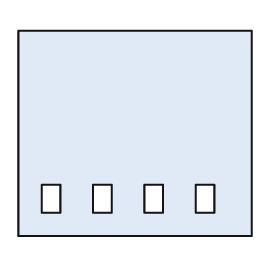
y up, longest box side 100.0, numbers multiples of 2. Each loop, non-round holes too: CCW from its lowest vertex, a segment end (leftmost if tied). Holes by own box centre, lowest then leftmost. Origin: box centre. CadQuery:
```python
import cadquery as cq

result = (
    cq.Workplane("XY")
    .moveTo(-50.0, -44.0)
    .lineTo(50.0, -44.0)
    .lineTo(50.0, 44.0)
    .lineTo(-50.0, 44.0)
    .close()
    .moveTo(-40.0, -34.0)
    .lineTo(-32.0, -34.0)
    .lineTo(-32.0, -22.0)
    .lineTo(-40.0, -22.0)
    .close()
    .moveTo(-18.0, -34.0)
    .lineTo(-10.0, -34.0)
    .lineTo(-10.0, -22.0)
    .lineTo(-18.0, -22.0)
    .close()
    .moveTo(4.0, -34.0)
    .lineTo(12.0, -34.0)
    .lineTo(12.0, -22.0)
    .lineTo(4.0, -22.0)
    .close()
    .moveTo(26.0, -34.0)
    .lineTo(34.0, -34.0)
    .lineTo(34.0, -22.0)
    .lineTo(26.0, -22.0)
    .close()
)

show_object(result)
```